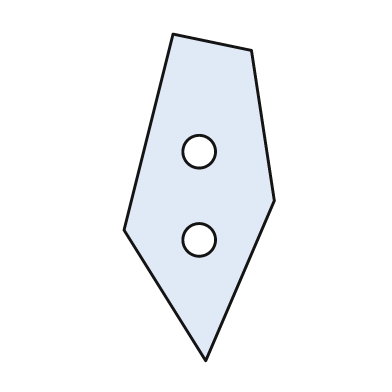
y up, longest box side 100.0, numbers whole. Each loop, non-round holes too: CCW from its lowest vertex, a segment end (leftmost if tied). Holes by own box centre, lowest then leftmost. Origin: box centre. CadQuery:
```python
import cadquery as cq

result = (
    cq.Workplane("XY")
    .moveTo(2.0, -50.0)
    .lineTo(23.0, -1.0)
    .lineTo(16.0, 45.0)
    .lineTo(-8.0, 50.0)
    .lineTo(-23.0, -10.0)
    .close()
    .moveTo(0.0, -13.0)
    .circle(5.0)
    .moveTo(0.0, 14.0)
    .circle(5.0)
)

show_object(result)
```